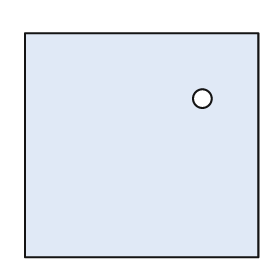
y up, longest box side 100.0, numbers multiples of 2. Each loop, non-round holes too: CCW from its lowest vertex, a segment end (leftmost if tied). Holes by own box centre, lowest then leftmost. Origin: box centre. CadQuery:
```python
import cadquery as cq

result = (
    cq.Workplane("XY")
    .moveTo(-50.0, -48.0)
    .lineTo(50.0, -48.0)
    .lineTo(50.0, 48.0)
    .lineTo(-50.0, 48.0)
    .close()
    .moveTo(26.0, 20.0)
    .circle(4.0)
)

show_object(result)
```